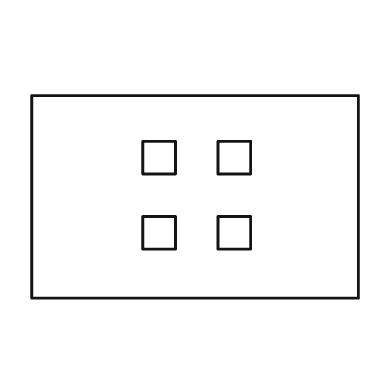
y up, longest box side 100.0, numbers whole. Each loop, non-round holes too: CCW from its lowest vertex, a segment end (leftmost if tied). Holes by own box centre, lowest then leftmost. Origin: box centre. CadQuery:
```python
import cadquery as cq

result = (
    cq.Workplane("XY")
    .moveTo(-50.0, -31.0)
    .lineTo(50.0, -31.0)
    .lineTo(50.0, 31.0)
    .lineTo(-50.0, 31.0)
    .close()
    .moveTo(-16.0, -16.0)
    .lineTo(-6.0, -16.0)
    .lineTo(-6.0, -6.0)
    .lineTo(-16.0, -6.0)
    .close()
    .moveTo(7.0, -16.0)
    .lineTo(17.0, -16.0)
    .lineTo(17.0, -6.0)
    .lineTo(7.0, -6.0)
    .close()
    .moveTo(-16.0, 7.0)
    .lineTo(-6.0, 7.0)
    .lineTo(-6.0, 17.0)
    .lineTo(-16.0, 17.0)
    .close()
    .moveTo(7.0, 7.0)
    .lineTo(17.0, 7.0)
    .lineTo(17.0, 17.0)
    .lineTo(7.0, 17.0)
    .close()
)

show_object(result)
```